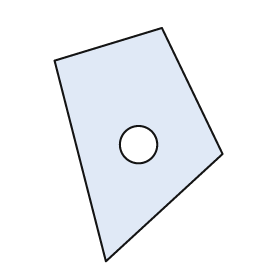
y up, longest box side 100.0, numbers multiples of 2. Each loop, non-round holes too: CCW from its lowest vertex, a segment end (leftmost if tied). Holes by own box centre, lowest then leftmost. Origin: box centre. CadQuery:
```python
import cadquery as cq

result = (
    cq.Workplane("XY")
    .moveTo(-14.0, -50.0)
    .lineTo(36.0, -4.0)
    .lineTo(10.0, 50.0)
    .lineTo(-36.0, 36.0)
    .close()
    .moveTo(0.0, 0.0)
    .circle(8.0)
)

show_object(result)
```